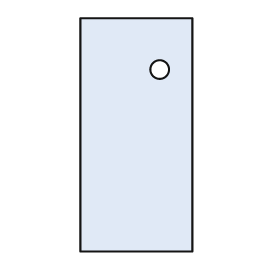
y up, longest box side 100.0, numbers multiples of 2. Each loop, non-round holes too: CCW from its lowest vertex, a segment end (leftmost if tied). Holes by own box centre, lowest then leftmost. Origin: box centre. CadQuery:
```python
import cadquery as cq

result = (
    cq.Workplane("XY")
    .moveTo(-24.0, -50.0)
    .lineTo(24.0, -50.0)
    .lineTo(24.0, 50.0)
    .lineTo(-24.0, 50.0)
    .close()
    .moveTo(10.0, 28.0)
    .circle(4.0)
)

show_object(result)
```